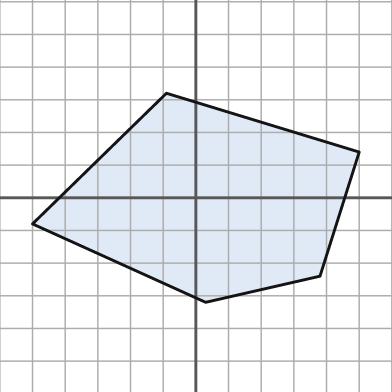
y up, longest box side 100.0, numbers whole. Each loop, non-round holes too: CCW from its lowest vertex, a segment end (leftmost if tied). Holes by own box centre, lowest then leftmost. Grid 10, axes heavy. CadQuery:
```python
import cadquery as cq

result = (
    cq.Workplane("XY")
    .moveTo(3.0, -32.0)
    .lineTo(38.0, -24.0)
    .lineTo(50.0, 14.0)
    .lineTo(-9.0, 32.0)
    .lineTo(-50.0, -8.0)
    .close()
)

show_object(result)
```